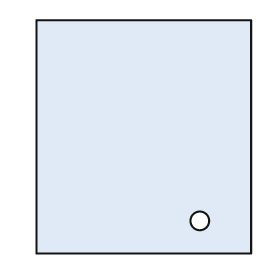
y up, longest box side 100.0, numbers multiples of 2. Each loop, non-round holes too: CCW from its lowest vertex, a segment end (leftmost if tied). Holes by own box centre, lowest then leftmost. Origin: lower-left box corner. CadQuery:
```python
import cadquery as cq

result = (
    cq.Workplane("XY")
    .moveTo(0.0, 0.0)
    .lineTo(92.0, 0.0)
    .lineTo(92.0, 100.0)
    .lineTo(0.0, 100.0)
    .close()
    .moveTo(70.0, 14.0)
    .circle(4.0)
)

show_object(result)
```